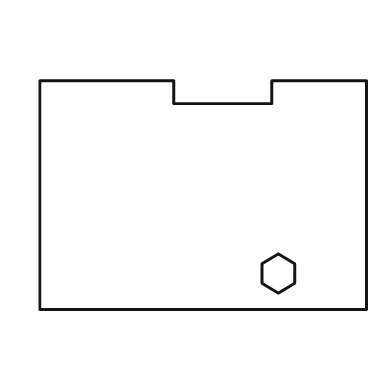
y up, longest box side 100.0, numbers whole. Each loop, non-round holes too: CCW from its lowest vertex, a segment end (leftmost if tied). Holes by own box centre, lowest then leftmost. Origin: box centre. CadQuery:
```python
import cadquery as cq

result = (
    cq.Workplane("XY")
    .moveTo(-50.0, -35.0)
    .lineTo(50.0, -35.0)
    .lineTo(50.0, 35.0)
    .lineTo(21.0, 35.0)
    .lineTo(21.0, 28.0)
    .lineTo(-9.0, 28.0)
    .lineTo(-9.0, 35.0)
    .lineTo(-50.0, 35.0)
    .close()
    .moveTo(23.0, -30.0)
    .lineTo(28.0, -27.0)
    .lineTo(28.0, -21.0)
    .lineTo(23.0, -18.0)
    .lineTo(18.0, -21.0)
    .lineTo(18.0, -27.0)
    .close()
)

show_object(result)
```